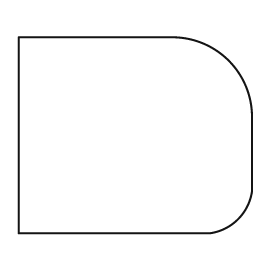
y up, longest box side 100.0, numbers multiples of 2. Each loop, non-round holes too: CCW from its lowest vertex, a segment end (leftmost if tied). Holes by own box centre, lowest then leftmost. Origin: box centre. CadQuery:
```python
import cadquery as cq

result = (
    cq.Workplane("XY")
    .moveTo(-50.0, -42.0)
    .lineTo(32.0, -42.0)
    .threePointArc((44.0, -36.0), (50.0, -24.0))
    .lineTo(50.0, 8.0)
    .threePointArc((40.0, 32.0), (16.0, 42.0))
    .lineTo(-50.0, 42.0)
    .close()
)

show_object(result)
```